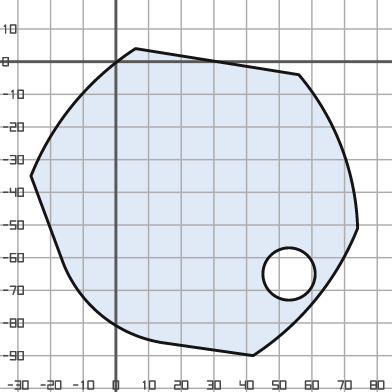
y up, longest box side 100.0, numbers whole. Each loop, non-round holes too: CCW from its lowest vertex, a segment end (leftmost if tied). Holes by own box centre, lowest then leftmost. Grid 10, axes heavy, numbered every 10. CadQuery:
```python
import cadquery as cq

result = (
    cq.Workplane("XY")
    .moveTo(42.0, -90.0)
    .threePointArc((61.0, -73.0), (74.0, -51.0))
    .threePointArc((69.0, -26.0), (56.0, -4.0))
    .lineTo(6.0, 4.0)
    .threePointArc((-13.0, -13.0), (-26.0, -35.0))
    .lineTo(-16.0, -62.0)
    .threePointArc((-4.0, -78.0), (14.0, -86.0))
    .close()
    .moveTo(53.0, -65.0)
    .circle(8.0)
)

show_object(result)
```